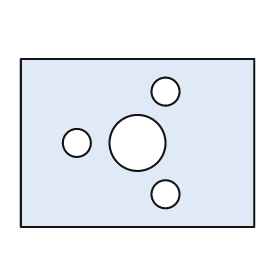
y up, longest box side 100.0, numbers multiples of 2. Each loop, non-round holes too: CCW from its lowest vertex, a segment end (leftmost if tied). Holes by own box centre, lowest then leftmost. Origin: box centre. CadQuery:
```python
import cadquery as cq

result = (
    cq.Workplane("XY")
    .moveTo(-50.0, -36.0)
    .lineTo(50.0, -36.0)
    .lineTo(50.0, 36.0)
    .lineTo(-50.0, 36.0)
    .close()
    .moveTo(12.0, -22.0)
    .circle(6.0)
    .moveTo(-26.0, 0.0)
    .circle(6.0)
    .moveTo(0.0, 0.0)
    .circle(12.0)
    .moveTo(12.0, 22.0)
    .circle(6.0)
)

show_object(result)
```